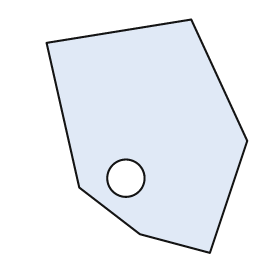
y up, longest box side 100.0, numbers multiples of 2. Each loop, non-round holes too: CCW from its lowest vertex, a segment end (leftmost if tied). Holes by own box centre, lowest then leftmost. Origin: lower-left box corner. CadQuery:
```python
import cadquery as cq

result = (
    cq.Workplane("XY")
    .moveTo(70.0, 0.0)
    .lineTo(86.0, 48.0)
    .lineTo(62.0, 100.0)
    .lineTo(0.0, 90.0)
    .lineTo(14.0, 28.0)
    .lineTo(40.0, 8.0)
    .close()
    .moveTo(34.0, 32.0)
    .circle(8.0)
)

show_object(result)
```